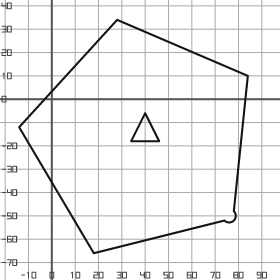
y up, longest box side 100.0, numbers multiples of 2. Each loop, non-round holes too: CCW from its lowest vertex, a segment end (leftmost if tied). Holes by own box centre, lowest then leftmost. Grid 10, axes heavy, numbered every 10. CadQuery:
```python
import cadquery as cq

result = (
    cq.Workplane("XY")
    .moveTo(18.0, -66.0)
    .lineTo(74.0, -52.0)
    .threePointArc((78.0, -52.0), (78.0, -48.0))
    .lineTo(84.0, 10.0)
    .lineTo(28.0, 34.0)
    .lineTo(-14.0, -12.0)
    .close()
    .moveTo(34.0, -18.0)
    .lineTo(46.0, -18.0)
    .lineTo(40.0, -6.0)
    .close()
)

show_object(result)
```